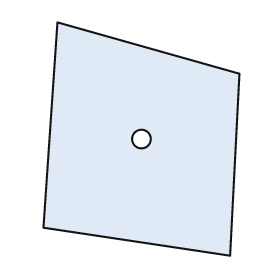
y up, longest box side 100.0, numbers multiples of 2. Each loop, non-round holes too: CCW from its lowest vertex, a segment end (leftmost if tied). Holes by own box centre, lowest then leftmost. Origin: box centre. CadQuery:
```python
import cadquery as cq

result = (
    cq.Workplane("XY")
    .moveTo(38.0, -50.0)
    .lineTo(42.0, 28.0)
    .lineTo(-36.0, 50.0)
    .lineTo(-42.0, -38.0)
    .close()
    .moveTo(0.0, 0.0)
    .circle(4.0)
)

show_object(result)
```